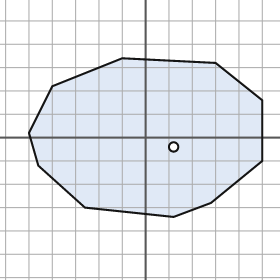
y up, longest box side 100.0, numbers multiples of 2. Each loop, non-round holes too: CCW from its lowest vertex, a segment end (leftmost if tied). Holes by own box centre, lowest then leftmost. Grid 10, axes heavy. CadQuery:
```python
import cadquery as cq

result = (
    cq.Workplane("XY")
    .moveTo(12.0, -34.0)
    .lineTo(28.0, -28.0)
    .lineTo(50.0, -10.0)
    .lineTo(50.0, 16.0)
    .lineTo(30.0, 32.0)
    .lineTo(-10.0, 34.0)
    .lineTo(-40.0, 22.0)
    .lineTo(-50.0, 2.0)
    .lineTo(-46.0, -12.0)
    .lineTo(-26.0, -30.0)
    .close()
    .moveTo(12.0, -4.0)
    .circle(2.0)
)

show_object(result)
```